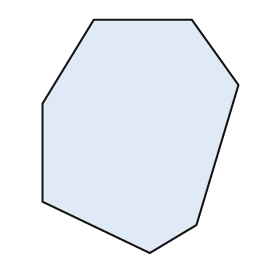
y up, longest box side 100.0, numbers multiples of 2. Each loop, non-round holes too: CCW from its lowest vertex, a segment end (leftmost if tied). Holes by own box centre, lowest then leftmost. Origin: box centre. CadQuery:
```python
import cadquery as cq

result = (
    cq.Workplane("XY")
    .moveTo(4.0, -50.0)
    .lineTo(24.0, -38.0)
    .lineTo(42.0, 22.0)
    .lineTo(22.0, 50.0)
    .lineTo(-20.0, 50.0)
    .lineTo(-42.0, 14.0)
    .lineTo(-42.0, -28.0)
    .close()
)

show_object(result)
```